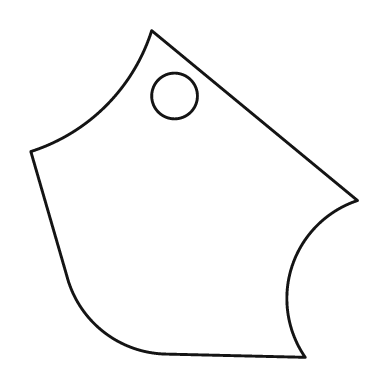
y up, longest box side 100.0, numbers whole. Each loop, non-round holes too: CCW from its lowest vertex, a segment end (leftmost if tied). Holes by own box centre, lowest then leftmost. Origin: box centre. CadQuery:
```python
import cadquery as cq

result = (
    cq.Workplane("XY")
    .moveTo(34.0, -50.0)
    .threePointArc((30.0, -22.0), (50.0, -2.0))
    .lineTo(-13.0, 50.0)
    .threePointArc((-27.0, 27.0), (-50.0, 13.0))
    .lineTo(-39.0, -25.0)
    .threePointArc((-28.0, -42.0), (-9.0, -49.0))
    .close()
    .moveTo(-6.0, 30.0)
    .circle(7.0)
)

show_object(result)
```